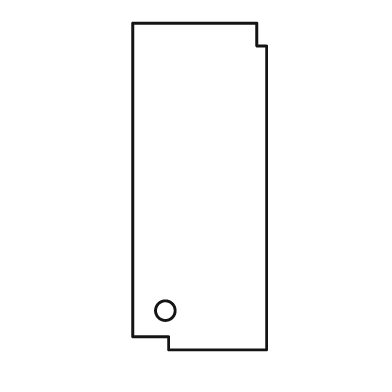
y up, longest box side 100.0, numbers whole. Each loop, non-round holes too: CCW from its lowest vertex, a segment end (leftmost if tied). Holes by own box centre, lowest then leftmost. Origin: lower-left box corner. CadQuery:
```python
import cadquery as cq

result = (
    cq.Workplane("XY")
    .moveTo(11.0, 0.0)
    .lineTo(41.0, 0.0)
    .lineTo(41.0, 93.0)
    .lineTo(38.0, 93.0)
    .lineTo(38.0, 100.0)
    .lineTo(0.0, 100.0)
    .lineTo(0.0, 4.0)
    .lineTo(11.0, 4.0)
    .close()
    .moveTo(10.0, 12.0)
    .circle(3.0)
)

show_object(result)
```